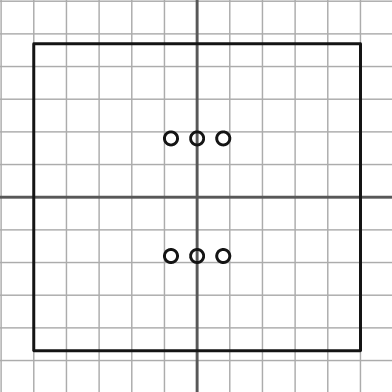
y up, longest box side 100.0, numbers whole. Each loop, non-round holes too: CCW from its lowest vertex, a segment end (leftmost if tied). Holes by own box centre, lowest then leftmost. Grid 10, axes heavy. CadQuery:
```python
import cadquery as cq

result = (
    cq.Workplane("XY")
    .moveTo(-50.0, -47.0)
    .lineTo(50.0, -47.0)
    .lineTo(50.0, 47.0)
    .lineTo(-50.0, 47.0)
    .close()
    .moveTo(-8.0, -18.0)
    .circle(2.0)
    .moveTo(0.0, -18.0)
    .circle(2.0)
    .moveTo(8.0, -18.0)
    .circle(2.0)
    .moveTo(-8.0, 18.0)
    .circle(2.0)
    .moveTo(0.0, 18.0)
    .circle(2.0)
    .moveTo(8.0, 18.0)
    .circle(2.0)
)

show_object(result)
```